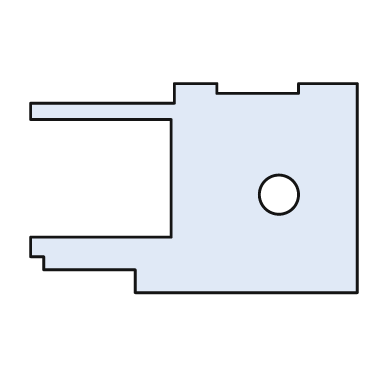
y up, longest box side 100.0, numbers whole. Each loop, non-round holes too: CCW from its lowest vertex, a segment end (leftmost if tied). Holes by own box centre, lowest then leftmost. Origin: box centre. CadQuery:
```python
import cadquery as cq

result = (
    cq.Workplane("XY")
    .moveTo(-18.0, -32.0)
    .lineTo(50.0, -32.0)
    .lineTo(50.0, 32.0)
    .lineTo(32.0, 32.0)
    .lineTo(32.0, 29.0)
    .lineTo(7.0, 29.0)
    .lineTo(7.0, 32.0)
    .lineTo(-6.0, 32.0)
    .lineTo(-6.0, 26.0)
    .lineTo(-50.0, 26.0)
    .lineTo(-50.0, 21.0)
    .lineTo(-7.0, 21.0)
    .lineTo(-7.0, -15.0)
    .lineTo(-50.0, -15.0)
    .lineTo(-50.0, -21.0)
    .lineTo(-46.0, -21.0)
    .lineTo(-46.0, -25.0)
    .lineTo(-18.0, -25.0)
    .close()
    .moveTo(26.0, -2.0)
    .circle(6.0)
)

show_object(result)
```